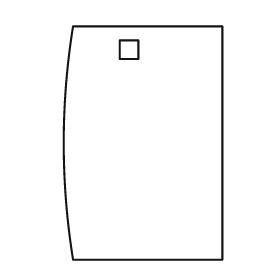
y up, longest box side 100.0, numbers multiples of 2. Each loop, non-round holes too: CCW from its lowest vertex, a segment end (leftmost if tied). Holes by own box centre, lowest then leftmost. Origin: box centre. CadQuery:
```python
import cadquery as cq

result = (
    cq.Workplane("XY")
    .moveTo(-30.0, -50.0)
    .lineTo(34.0, -50.0)
    .lineTo(34.0, 50.0)
    .lineTo(-30.0, 50.0)
    .threePointArc((-34.0, 0.0), (-30.0, -50.0))
    .close()
    .moveTo(-10.0, 36.0)
    .lineTo(-2.0, 36.0)
    .lineTo(-2.0, 44.0)
    .lineTo(-10.0, 44.0)
    .close()
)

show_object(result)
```